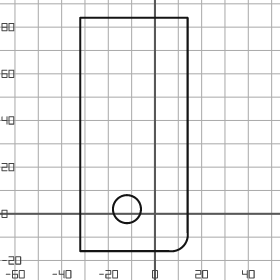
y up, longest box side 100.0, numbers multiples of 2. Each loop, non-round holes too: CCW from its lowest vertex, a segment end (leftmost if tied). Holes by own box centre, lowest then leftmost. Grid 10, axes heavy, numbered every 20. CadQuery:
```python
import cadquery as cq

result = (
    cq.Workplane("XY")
    .moveTo(-32.0, -16.0)
    .lineTo(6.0, -16.0)
    .threePointArc((12.0, -14.0), (14.0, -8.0))
    .lineTo(14.0, 84.0)
    .lineTo(-32.0, 84.0)
    .close()
    .moveTo(-12.0, 2.0)
    .circle(6.0)
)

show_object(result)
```